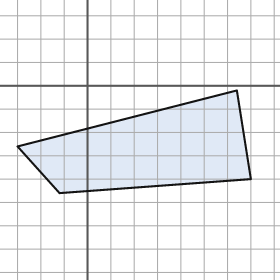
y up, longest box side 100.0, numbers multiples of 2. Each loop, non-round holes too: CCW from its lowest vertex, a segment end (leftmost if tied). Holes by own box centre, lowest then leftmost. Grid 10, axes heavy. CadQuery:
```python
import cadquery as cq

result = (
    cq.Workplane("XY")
    .moveTo(-12.0, -46.0)
    .lineTo(70.0, -40.0)
    .lineTo(64.0, -2.0)
    .lineTo(-30.0, -26.0)
    .close()
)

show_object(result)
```